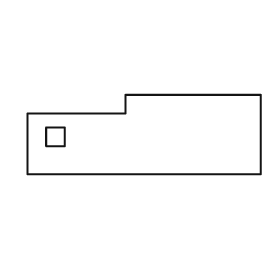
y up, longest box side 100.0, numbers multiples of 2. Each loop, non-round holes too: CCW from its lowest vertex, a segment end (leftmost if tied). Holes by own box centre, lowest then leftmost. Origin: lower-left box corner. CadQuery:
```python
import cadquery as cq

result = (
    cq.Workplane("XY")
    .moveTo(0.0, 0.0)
    .lineTo(100.0, 0.0)
    .lineTo(100.0, 34.0)
    .lineTo(42.0, 34.0)
    .lineTo(42.0, 26.0)
    .lineTo(0.0, 26.0)
    .close()
    .moveTo(8.0, 12.0)
    .lineTo(16.0, 12.0)
    .lineTo(16.0, 20.0)
    .lineTo(8.0, 20.0)
    .close()
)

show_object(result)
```